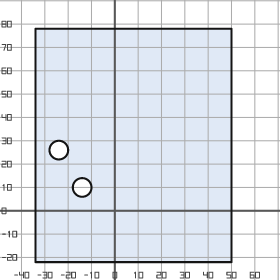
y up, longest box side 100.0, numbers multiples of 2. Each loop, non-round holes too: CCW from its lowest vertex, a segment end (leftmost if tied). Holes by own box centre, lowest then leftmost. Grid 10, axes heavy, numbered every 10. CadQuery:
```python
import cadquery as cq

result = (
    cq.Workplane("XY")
    .moveTo(-34.0, -22.0)
    .lineTo(50.0, -22.0)
    .lineTo(50.0, 78.0)
    .lineTo(-34.0, 78.0)
    .close()
    .moveTo(-14.0, 10.0)
    .circle(4.0)
    .moveTo(-24.0, 26.0)
    .circle(4.0)
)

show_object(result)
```